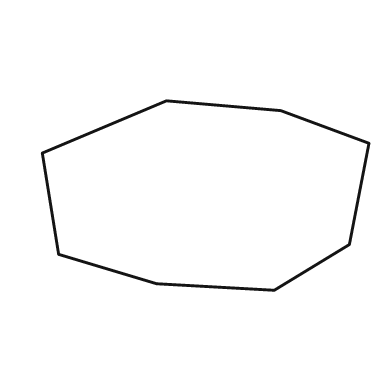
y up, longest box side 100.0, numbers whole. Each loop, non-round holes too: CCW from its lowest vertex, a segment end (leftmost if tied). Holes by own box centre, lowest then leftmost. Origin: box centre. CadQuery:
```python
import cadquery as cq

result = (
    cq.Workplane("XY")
    .moveTo(21.0, -29.0)
    .lineTo(44.0, -15.0)
    .lineTo(50.0, 16.0)
    .lineTo(23.0, 26.0)
    .lineTo(-12.0, 29.0)
    .lineTo(-50.0, 13.0)
    .lineTo(-45.0, -18.0)
    .lineTo(-15.0, -27.0)
    .close()
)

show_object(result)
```